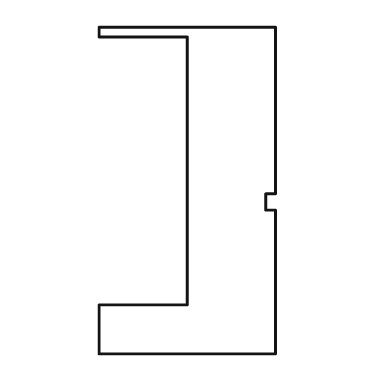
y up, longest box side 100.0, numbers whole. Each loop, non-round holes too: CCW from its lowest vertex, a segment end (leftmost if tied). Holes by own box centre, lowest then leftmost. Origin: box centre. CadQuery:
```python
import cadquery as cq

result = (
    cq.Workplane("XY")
    .moveTo(-27.0, -50.0)
    .lineTo(27.0, -50.0)
    .lineTo(27.0, -6.0)
    .lineTo(24.0, -6.0)
    .lineTo(24.0, -1.0)
    .lineTo(27.0, -1.0)
    .lineTo(27.0, 50.0)
    .lineTo(-27.0, 50.0)
    .lineTo(-27.0, 47.0)
    .lineTo(0.0, 47.0)
    .lineTo(0.0, -35.0)
    .lineTo(-27.0, -35.0)
    .close()
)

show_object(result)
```